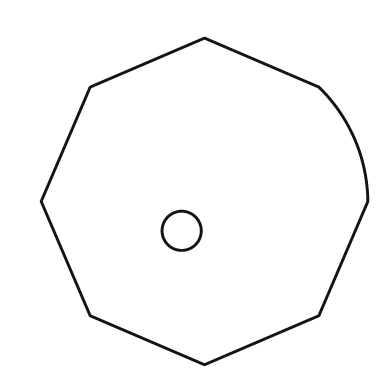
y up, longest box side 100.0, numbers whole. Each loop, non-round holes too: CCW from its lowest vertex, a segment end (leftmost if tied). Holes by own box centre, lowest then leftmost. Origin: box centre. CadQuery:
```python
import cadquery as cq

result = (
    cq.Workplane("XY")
    .moveTo(0.0, -50.0)
    .lineTo(35.0, -35.0)
    .lineTo(50.0, 0.0)
    .threePointArc((46.0, 19.0), (35.0, 35.0))
    .lineTo(0.0, 50.0)
    .lineTo(-35.0, 35.0)
    .lineTo(-50.0, 0.0)
    .lineTo(-35.0, -35.0)
    .close()
    .moveTo(-7.0, -9.0)
    .circle(6.0)
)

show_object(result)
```